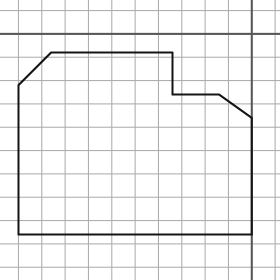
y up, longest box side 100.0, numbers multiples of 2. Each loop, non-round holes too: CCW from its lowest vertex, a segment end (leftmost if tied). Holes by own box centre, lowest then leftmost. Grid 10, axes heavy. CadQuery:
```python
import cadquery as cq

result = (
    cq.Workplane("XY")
    .moveTo(-100.0, -86.0)
    .lineTo(0.0, -86.0)
    .lineTo(0.0, -36.0)
    .lineTo(-14.0, -26.0)
    .lineTo(-34.0, -26.0)
    .lineTo(-34.0, -8.0)
    .lineTo(-86.0, -8.0)
    .lineTo(-100.0, -22.0)
    .close()
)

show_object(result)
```